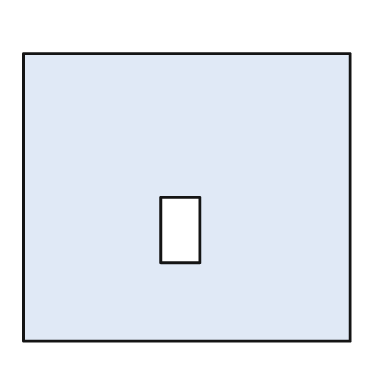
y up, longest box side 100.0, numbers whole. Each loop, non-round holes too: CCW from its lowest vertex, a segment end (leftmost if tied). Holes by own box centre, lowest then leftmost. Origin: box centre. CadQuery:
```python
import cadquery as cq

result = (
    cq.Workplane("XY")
    .moveTo(-50.0, -44.0)
    .lineTo(50.0, -44.0)
    .lineTo(50.0, 44.0)
    .lineTo(-50.0, 44.0)
    .close()
    .moveTo(-8.0, -20.0)
    .lineTo(4.0, -20.0)
    .lineTo(4.0, 0.0)
    .lineTo(-8.0, 0.0)
    .close()
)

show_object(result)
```